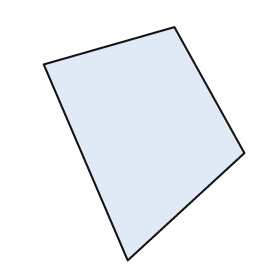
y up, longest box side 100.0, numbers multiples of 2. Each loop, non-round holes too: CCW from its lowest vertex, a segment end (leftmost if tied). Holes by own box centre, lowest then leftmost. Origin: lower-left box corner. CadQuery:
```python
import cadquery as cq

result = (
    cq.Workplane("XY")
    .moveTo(36.0, 0.0)
    .lineTo(86.0, 46.0)
    .lineTo(56.0, 100.0)
    .lineTo(0.0, 84.0)
    .close()
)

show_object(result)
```